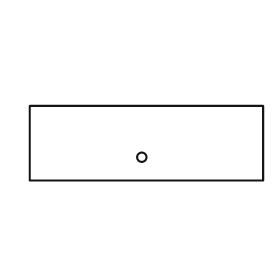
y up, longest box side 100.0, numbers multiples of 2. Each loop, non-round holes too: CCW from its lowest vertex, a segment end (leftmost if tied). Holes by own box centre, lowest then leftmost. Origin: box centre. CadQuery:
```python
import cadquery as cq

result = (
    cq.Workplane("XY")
    .moveTo(-50.0, -16.0)
    .lineTo(50.0, -16.0)
    .lineTo(50.0, 16.0)
    .lineTo(-50.0, 16.0)
    .close()
    .moveTo(-2.0, -6.0)
    .circle(2.0)
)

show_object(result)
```